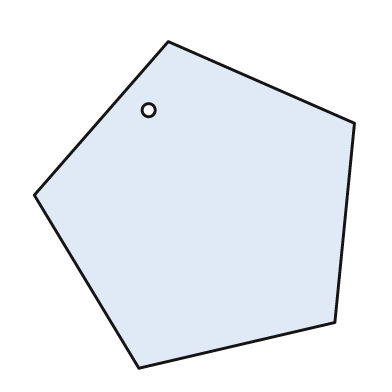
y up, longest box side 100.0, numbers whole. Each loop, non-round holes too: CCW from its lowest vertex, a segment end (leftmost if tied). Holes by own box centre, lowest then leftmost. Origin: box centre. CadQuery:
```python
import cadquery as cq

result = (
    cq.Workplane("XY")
    .moveTo(-17.0, -50.0)
    .lineTo(43.0, -36.0)
    .lineTo(49.0, 25.0)
    .lineTo(-8.0, 50.0)
    .lineTo(-49.0, 3.0)
    .close()
    .moveTo(-14.0, 29.0)
    .circle(2.0)
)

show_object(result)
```